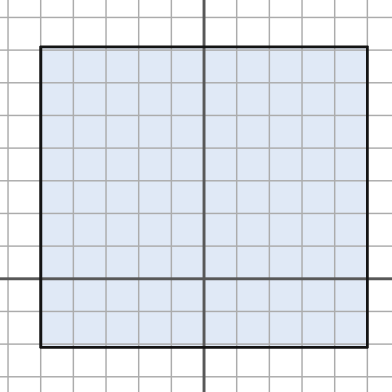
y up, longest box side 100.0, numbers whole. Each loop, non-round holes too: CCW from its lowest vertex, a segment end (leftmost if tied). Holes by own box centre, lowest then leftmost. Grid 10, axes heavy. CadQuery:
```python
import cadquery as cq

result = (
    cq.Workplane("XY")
    .moveTo(-50.0, -21.0)
    .lineTo(50.0, -21.0)
    .lineTo(50.0, 71.0)
    .lineTo(-50.0, 71.0)
    .close()
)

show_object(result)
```